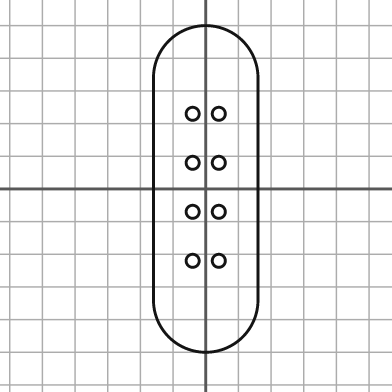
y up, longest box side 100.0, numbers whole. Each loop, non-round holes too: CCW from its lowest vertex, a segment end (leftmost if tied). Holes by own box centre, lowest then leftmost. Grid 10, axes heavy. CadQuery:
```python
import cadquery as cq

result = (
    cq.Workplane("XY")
    .moveTo(-16.0, -34.0)
    .threePointArc((0.0, -50.0), (16.0, -34.0))
    .lineTo(16.0, 34.0)
    .threePointArc((0.0, 50.0), (-16.0, 34.0))
    .close()
    .moveTo(-4.0, -22.0)
    .circle(2.0)
    .moveTo(4.0, -22.0)
    .circle(2.0)
    .moveTo(-4.0, -7.0)
    .circle(2.0)
    .moveTo(4.0, -7.0)
    .circle(2.0)
    .moveTo(-4.0, 8.0)
    .circle(2.0)
    .moveTo(4.0, 8.0)
    .circle(2.0)
    .moveTo(-4.0, 23.0)
    .circle(2.0)
    .moveTo(4.0, 23.0)
    .circle(2.0)
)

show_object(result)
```